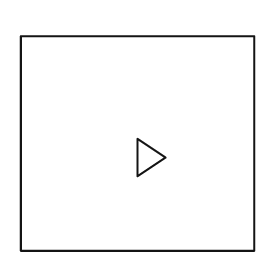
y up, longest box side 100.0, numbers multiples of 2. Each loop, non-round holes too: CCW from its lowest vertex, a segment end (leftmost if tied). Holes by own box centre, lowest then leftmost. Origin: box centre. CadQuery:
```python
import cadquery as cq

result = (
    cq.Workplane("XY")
    .moveTo(-50.0, -46.0)
    .lineTo(50.0, -46.0)
    .lineTo(50.0, 46.0)
    .lineTo(-50.0, 46.0)
    .close()
    .moveTo(0.0, -14.0)
    .lineTo(12.0, -6.0)
    .lineTo(0.0, 2.0)
    .close()
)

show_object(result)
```